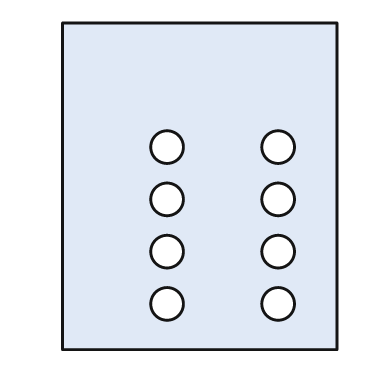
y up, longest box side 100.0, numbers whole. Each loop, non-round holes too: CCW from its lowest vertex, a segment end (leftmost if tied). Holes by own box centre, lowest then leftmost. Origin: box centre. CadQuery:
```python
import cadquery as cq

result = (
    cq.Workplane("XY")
    .moveTo(-42.0, -50.0)
    .lineTo(42.0, -50.0)
    .lineTo(42.0, 50.0)
    .lineTo(-42.0, 50.0)
    .close()
    .moveTo(-10.0, -36.0)
    .circle(5.0)
    .moveTo(24.0, -36.0)
    .circle(5.0)
    .moveTo(-10.0, -20.0)
    .circle(5.0)
    .moveTo(24.0, -20.0)
    .circle(5.0)
    .moveTo(-10.0, -4.0)
    .circle(5.0)
    .moveTo(24.0, -4.0)
    .circle(5.0)
    .moveTo(-10.0, 12.0)
    .circle(5.0)
    .moveTo(24.0, 12.0)
    .circle(5.0)
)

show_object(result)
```